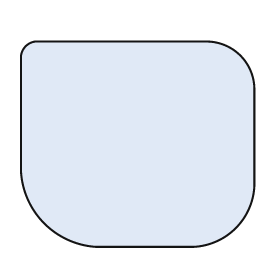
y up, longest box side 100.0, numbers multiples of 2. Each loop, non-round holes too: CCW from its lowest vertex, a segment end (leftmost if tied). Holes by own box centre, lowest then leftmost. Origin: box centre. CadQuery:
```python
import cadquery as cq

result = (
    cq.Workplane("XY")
    .moveTo(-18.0, -44.0)
    .lineTo(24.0, -44.0)
    .threePointArc((42.0, -36.0), (50.0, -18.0))
    .lineTo(50.0, 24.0)
    .threePointArc((44.0, 38.0), (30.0, 44.0))
    .lineTo(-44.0, 44.0)
    .threePointArc((-48.0, 42.0), (-50.0, 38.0))
    .lineTo(-50.0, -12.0)
    .threePointArc((-40.0, -34.0), (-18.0, -44.0))
    .close()
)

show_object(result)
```